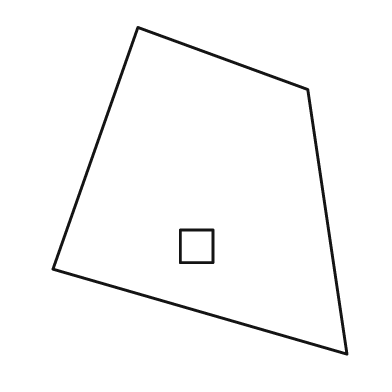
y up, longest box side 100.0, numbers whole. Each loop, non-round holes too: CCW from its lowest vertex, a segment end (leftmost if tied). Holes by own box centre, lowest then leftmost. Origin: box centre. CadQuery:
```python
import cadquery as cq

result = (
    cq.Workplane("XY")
    .moveTo(45.0, -50.0)
    .lineTo(33.0, 31.0)
    .lineTo(-19.0, 50.0)
    .lineTo(-45.0, -24.0)
    .close()
    .moveTo(-6.0, -22.0)
    .lineTo(4.0, -22.0)
    .lineTo(4.0, -12.0)
    .lineTo(-6.0, -12.0)
    .close()
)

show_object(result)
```